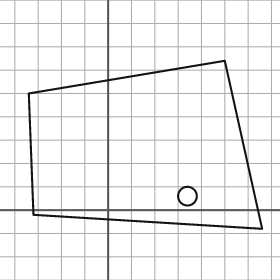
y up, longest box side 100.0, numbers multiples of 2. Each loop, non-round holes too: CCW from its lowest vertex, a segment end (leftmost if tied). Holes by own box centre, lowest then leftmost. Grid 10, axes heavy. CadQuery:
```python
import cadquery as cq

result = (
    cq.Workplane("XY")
    .moveTo(66.0, -8.0)
    .lineTo(50.0, 64.0)
    .lineTo(-34.0, 50.0)
    .lineTo(-32.0, -2.0)
    .close()
    .moveTo(34.0, 6.0)
    .circle(4.0)
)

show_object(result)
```